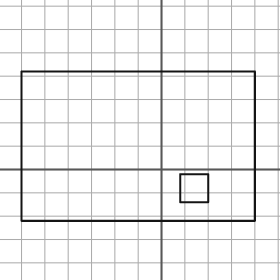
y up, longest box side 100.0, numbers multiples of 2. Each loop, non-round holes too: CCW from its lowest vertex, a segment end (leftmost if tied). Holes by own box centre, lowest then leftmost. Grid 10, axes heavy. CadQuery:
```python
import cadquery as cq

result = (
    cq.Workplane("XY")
    .moveTo(-60.0, -22.0)
    .lineTo(40.0, -22.0)
    .lineTo(40.0, 42.0)
    .lineTo(-60.0, 42.0)
    .close()
    .moveTo(8.0, -14.0)
    .lineTo(20.0, -14.0)
    .lineTo(20.0, -2.0)
    .lineTo(8.0, -2.0)
    .close()
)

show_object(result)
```